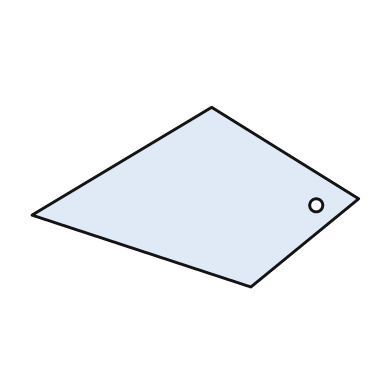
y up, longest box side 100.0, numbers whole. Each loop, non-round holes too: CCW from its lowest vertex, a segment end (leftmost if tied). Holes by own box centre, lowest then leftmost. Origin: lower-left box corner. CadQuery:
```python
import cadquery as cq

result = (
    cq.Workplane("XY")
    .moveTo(67.0, 0.0)
    .lineTo(100.0, 27.0)
    .lineTo(55.0, 55.0)
    .lineTo(0.0, 22.0)
    .close()
    .moveTo(87.0, 25.0)
    .circle(2.0)
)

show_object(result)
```